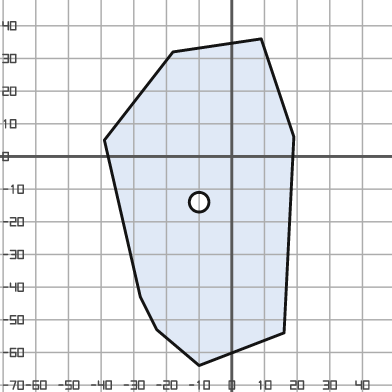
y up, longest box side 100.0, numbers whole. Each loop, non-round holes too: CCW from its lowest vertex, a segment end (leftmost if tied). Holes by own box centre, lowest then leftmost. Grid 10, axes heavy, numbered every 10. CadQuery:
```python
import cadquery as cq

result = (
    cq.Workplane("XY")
    .moveTo(-10.0, -64.0)
    .lineTo(16.0, -54.0)
    .lineTo(19.0, 6.0)
    .lineTo(9.0, 36.0)
    .lineTo(-18.0, 32.0)
    .lineTo(-39.0, 5.0)
    .lineTo(-28.0, -43.0)
    .lineTo(-23.0, -53.0)
    .close()
    .moveTo(-10.0, -14.0)
    .circle(3.0)
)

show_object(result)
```